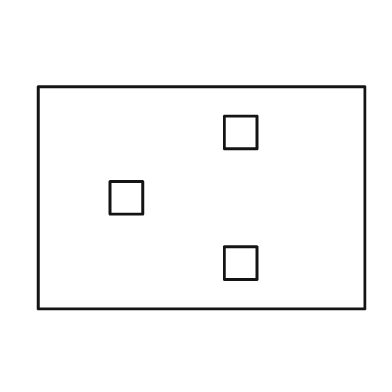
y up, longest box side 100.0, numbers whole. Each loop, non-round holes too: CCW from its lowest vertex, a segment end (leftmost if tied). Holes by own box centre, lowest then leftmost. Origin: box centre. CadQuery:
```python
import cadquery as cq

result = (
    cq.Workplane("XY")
    .moveTo(-50.0, -34.0)
    .lineTo(50.0, -34.0)
    .lineTo(50.0, 34.0)
    .lineTo(-50.0, 34.0)
    .close()
    .moveTo(7.0, -25.0)
    .lineTo(17.0, -25.0)
    .lineTo(17.0, -15.0)
    .lineTo(7.0, -15.0)
    .close()
    .moveTo(-28.0, -5.0)
    .lineTo(-18.0, -5.0)
    .lineTo(-18.0, 5.0)
    .lineTo(-28.0, 5.0)
    .close()
    .moveTo(7.0, 15.0)
    .lineTo(17.0, 15.0)
    .lineTo(17.0, 25.0)
    .lineTo(7.0, 25.0)
    .close()
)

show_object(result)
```